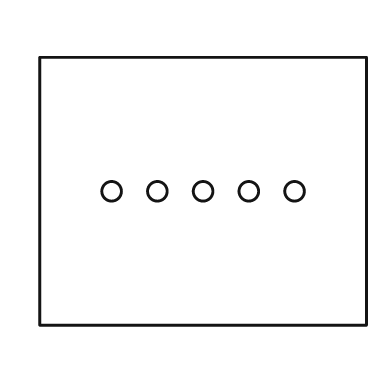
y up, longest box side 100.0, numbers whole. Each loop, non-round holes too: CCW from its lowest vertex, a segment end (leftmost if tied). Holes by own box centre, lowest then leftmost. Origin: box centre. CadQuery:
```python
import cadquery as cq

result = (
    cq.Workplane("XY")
    .moveTo(-50.0, -41.0)
    .lineTo(50.0, -41.0)
    .lineTo(50.0, 41.0)
    .lineTo(-50.0, 41.0)
    .close()
    .moveTo(-28.0, 0.0)
    .circle(3.0)
    .moveTo(-14.0, 0.0)
    .circle(3.0)
    .moveTo(0.0, 0.0)
    .circle(3.0)
    .moveTo(14.0, 0.0)
    .circle(3.0)
    .moveTo(28.0, 0.0)
    .circle(3.0)
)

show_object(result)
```